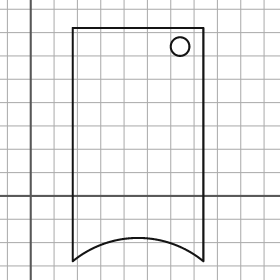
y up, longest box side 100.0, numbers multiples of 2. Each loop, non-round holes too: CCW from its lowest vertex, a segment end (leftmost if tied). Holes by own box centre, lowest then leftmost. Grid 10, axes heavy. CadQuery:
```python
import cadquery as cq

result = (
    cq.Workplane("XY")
    .moveTo(18.0, -28.0)
    .threePointArc((46.0, -18.0), (74.0, -28.0))
    .lineTo(74.0, 72.0)
    .lineTo(18.0, 72.0)
    .close()
    .moveTo(64.0, 64.0)
    .circle(4.0)
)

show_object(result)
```